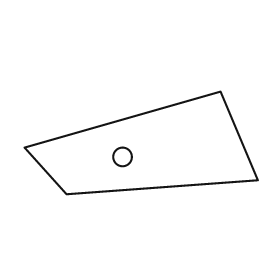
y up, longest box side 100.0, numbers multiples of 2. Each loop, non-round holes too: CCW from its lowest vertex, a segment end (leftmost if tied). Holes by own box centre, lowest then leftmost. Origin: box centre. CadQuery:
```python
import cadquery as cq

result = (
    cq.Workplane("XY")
    .moveTo(-32.0, -22.0)
    .lineTo(50.0, -16.0)
    .lineTo(34.0, 22.0)
    .lineTo(-50.0, -2.0)
    .close()
    .moveTo(-8.0, -6.0)
    .circle(4.0)
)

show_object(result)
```